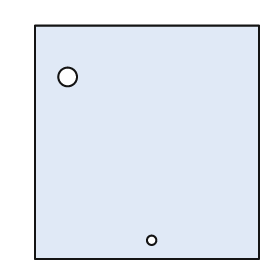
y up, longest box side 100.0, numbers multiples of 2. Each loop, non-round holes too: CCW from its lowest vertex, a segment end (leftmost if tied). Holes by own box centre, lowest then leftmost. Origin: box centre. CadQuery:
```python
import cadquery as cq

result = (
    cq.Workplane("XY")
    .moveTo(-48.0, -50.0)
    .lineTo(48.0, -50.0)
    .lineTo(48.0, 50.0)
    .lineTo(-48.0, 50.0)
    .close()
    .moveTo(2.0, -42.0)
    .circle(2.0)
    .moveTo(-34.0, 28.0)
    .circle(4.0)
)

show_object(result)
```